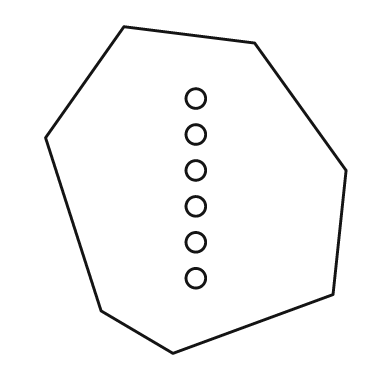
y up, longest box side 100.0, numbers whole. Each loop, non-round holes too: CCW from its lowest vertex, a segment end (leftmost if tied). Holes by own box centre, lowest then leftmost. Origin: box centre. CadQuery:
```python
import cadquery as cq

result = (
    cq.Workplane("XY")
    .moveTo(-7.0, -50.0)
    .lineTo(42.0, -32.0)
    .lineTo(46.0, 6.0)
    .lineTo(18.0, 45.0)
    .lineTo(-22.0, 50.0)
    .lineTo(-46.0, 16.0)
    .lineTo(-29.0, -37.0)
    .close()
    .moveTo(0.0, -27.0)
    .circle(3.0)
    .moveTo(0.0, -16.0)
    .circle(3.0)
    .moveTo(0.0, -5.0)
    .circle(3.0)
    .moveTo(0.0, 6.0)
    .circle(3.0)
    .moveTo(0.0, 17.0)
    .circle(3.0)
    .moveTo(0.0, 28.0)
    .circle(3.0)
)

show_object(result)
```